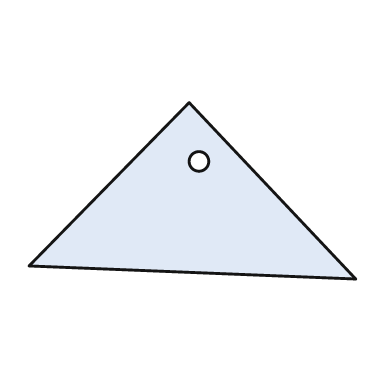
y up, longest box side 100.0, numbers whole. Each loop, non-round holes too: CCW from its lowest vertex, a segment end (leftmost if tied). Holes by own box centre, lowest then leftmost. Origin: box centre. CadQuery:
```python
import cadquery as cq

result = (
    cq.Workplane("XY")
    .moveTo(50.0, -27.0)
    .lineTo(-1.0, 27.0)
    .lineTo(-50.0, -23.0)
    .close()
    .moveTo(2.0, 9.0)
    .circle(3.0)
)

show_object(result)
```